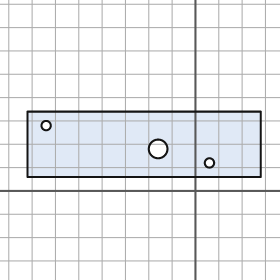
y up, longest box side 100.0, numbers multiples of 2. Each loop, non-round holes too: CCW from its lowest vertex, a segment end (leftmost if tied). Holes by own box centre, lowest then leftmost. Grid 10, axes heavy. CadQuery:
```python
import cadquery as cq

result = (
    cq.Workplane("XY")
    .moveTo(-72.0, 6.0)
    .lineTo(28.0, 6.0)
    .lineTo(28.0, 34.0)
    .lineTo(-72.0, 34.0)
    .close()
    .moveTo(6.0, 12.0)
    .circle(2.0)
    .moveTo(-16.0, 18.0)
    .circle(4.0)
    .moveTo(-64.0, 28.0)
    .circle(2.0)
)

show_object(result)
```